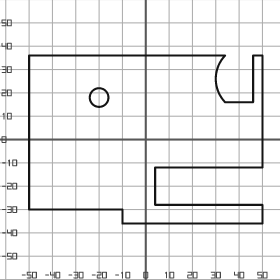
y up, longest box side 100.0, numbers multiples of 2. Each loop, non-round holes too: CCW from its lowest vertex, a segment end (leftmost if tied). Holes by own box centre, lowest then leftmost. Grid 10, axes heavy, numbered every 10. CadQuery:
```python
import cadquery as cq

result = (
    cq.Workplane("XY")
    .moveTo(-10.0, -36.0)
    .lineTo(50.0, -36.0)
    .lineTo(50.0, -28.0)
    .lineTo(4.0, -28.0)
    .lineTo(4.0, -12.0)
    .lineTo(50.0, -12.0)
    .lineTo(50.0, 36.0)
    .lineTo(46.0, 36.0)
    .lineTo(46.0, 16.0)
    .lineTo(34.0, 16.0)
    .threePointArc((30.0, 26.0), (34.0, 36.0))
    .lineTo(-50.0, 36.0)
    .lineTo(-50.0, -30.0)
    .lineTo(-10.0, -30.0)
    .close()
    .moveTo(-20.0, 18.0)
    .circle(4.0)
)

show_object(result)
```